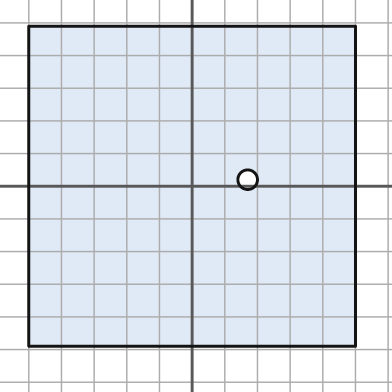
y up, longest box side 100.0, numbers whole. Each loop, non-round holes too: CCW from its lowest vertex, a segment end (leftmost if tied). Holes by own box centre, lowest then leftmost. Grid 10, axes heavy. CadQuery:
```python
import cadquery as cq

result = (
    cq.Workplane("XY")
    .moveTo(-50.0, -49.0)
    .lineTo(50.0, -49.0)
    .lineTo(50.0, 49.0)
    .lineTo(-50.0, 49.0)
    .close()
    .moveTo(17.0, 2.0)
    .circle(3.0)
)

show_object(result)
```